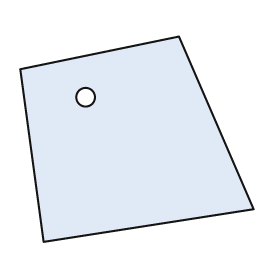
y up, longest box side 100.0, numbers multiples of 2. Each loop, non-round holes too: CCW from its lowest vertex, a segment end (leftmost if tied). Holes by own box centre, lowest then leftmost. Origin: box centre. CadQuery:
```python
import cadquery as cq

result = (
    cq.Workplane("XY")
    .moveTo(-40.0, -44.0)
    .lineTo(50.0, -30.0)
    .lineTo(18.0, 44.0)
    .lineTo(-50.0, 30.0)
    .close()
    .moveTo(-22.0, 18.0)
    .circle(4.0)
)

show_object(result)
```